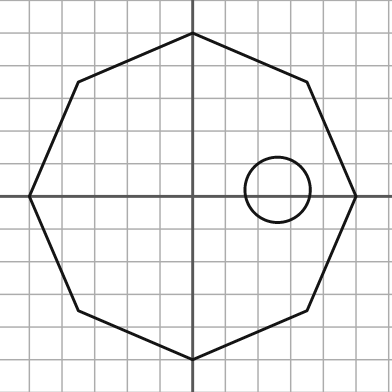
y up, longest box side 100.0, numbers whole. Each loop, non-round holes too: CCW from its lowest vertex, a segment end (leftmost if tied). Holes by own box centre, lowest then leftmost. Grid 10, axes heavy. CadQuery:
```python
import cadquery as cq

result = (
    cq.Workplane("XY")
    .moveTo(0.0, -50.0)
    .lineTo(35.0, -35.0)
    .lineTo(50.0, 0.0)
    .lineTo(35.0, 35.0)
    .lineTo(0.0, 50.0)
    .lineTo(-35.0, 35.0)
    .lineTo(-50.0, 0.0)
    .lineTo(-35.0, -35.0)
    .close()
    .moveTo(26.0, 2.0)
    .circle(10.0)
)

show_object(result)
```